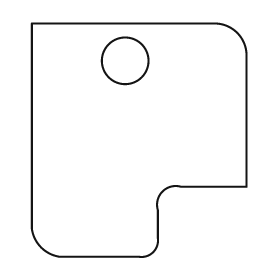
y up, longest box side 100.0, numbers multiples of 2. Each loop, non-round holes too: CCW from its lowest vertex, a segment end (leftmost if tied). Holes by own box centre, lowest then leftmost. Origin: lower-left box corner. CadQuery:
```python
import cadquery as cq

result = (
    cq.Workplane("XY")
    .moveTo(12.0, 0.0)
    .lineTo(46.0, 0.0)
    .threePointArc((52.0, 2.0), (54.0, 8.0))
    .lineTo(54.0, 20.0)
    .threePointArc((56.0, 28.0), (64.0, 30.0))
    .lineTo(92.0, 30.0)
    .lineTo(92.0, 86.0)
    .threePointArc((88.0, 96.0), (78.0, 100.0))
    .lineTo(0.0, 100.0)
    .lineTo(0.0, 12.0)
    .threePointArc((4.0, 4.0), (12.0, 0.0))
    .close()
    .moveTo(40.0, 84.0)
    .circle(10.0)
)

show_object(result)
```